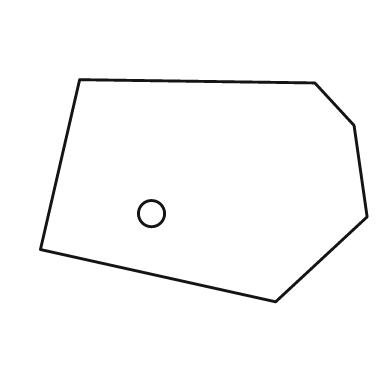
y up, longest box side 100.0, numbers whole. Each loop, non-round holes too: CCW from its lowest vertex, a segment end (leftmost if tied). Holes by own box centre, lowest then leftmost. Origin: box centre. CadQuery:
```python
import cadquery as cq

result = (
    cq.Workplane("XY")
    .moveTo(22.0, -34.0)
    .lineTo(50.0, -8.0)
    .lineTo(46.0, 20.0)
    .lineTo(34.0, 33.0)
    .lineTo(-38.0, 34.0)
    .lineTo(-50.0, -18.0)
    .close()
    .moveTo(-16.0, -7.0)
    .circle(4.0)
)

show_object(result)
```